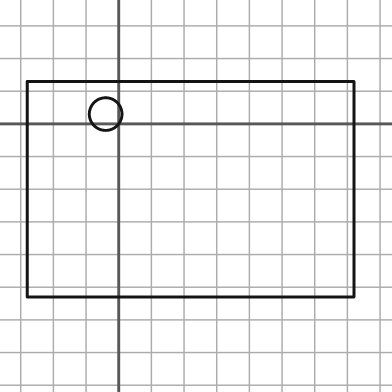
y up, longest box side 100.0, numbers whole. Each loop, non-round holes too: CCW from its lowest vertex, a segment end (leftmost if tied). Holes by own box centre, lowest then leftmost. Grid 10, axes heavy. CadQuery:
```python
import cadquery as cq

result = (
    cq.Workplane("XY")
    .moveTo(-28.0, -53.0)
    .lineTo(72.0, -53.0)
    .lineTo(72.0, 13.0)
    .lineTo(-28.0, 13.0)
    .close()
    .moveTo(-4.0, 3.0)
    .circle(5.0)
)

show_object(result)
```